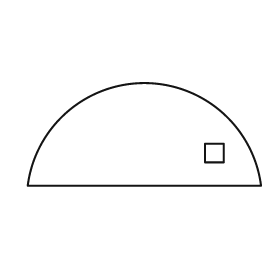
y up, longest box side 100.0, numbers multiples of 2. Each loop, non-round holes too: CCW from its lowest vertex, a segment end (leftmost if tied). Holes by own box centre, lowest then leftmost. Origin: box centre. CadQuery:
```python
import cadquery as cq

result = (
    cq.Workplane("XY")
    .moveTo(-50.0, -22.0)
    .lineTo(50.0, -22.0)
    .threePointArc((0.0, 22.0), (-50.0, -22.0))
    .close()
    .moveTo(26.0, -12.0)
    .lineTo(34.0, -12.0)
    .lineTo(34.0, -4.0)
    .lineTo(26.0, -4.0)
    .close()
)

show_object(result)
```